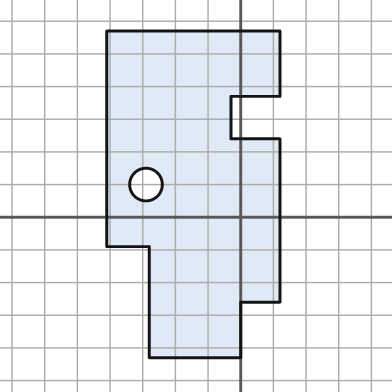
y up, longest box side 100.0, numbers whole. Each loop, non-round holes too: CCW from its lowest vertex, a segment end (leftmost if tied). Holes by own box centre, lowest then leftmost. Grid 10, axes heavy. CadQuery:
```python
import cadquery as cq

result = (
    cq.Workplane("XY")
    .moveTo(-28.0, -43.0)
    .lineTo(0.0, -43.0)
    .lineTo(0.0, -26.0)
    .lineTo(12.0, -26.0)
    .lineTo(12.0, 24.0)
    .lineTo(-3.0, 24.0)
    .lineTo(-3.0, 37.0)
    .lineTo(12.0, 37.0)
    .lineTo(12.0, 57.0)
    .lineTo(-41.0, 57.0)
    .lineTo(-41.0, -9.0)
    .lineTo(-28.0, -9.0)
    .close()
    .moveTo(-29.0, 10.0)
    .circle(5.0)
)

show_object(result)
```